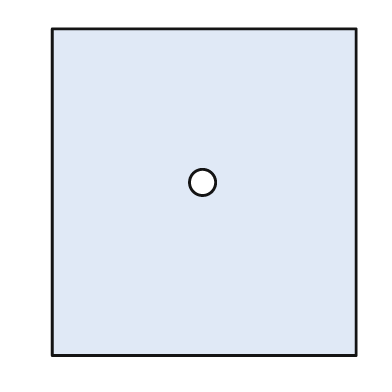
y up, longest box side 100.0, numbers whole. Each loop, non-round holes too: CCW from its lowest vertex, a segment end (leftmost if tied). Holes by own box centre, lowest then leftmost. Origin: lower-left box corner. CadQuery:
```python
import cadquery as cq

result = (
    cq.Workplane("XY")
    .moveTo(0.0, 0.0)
    .lineTo(93.0, 0.0)
    .lineTo(93.0, 100.0)
    .lineTo(0.0, 100.0)
    .close()
    .moveTo(46.0, 53.0)
    .circle(4.0)
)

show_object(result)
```